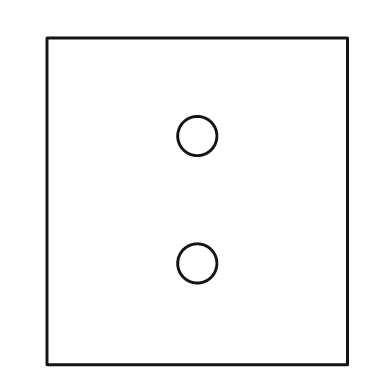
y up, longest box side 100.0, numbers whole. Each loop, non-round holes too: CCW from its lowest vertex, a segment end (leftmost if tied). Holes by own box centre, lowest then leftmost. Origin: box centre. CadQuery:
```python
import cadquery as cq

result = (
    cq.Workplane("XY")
    .moveTo(-46.0, -50.0)
    .lineTo(46.0, -50.0)
    .lineTo(46.0, 50.0)
    .lineTo(-46.0, 50.0)
    .close()
    .moveTo(0.0, -19.0)
    .circle(6.0)
    .moveTo(0.0, 20.0)
    .circle(6.0)
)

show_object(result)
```